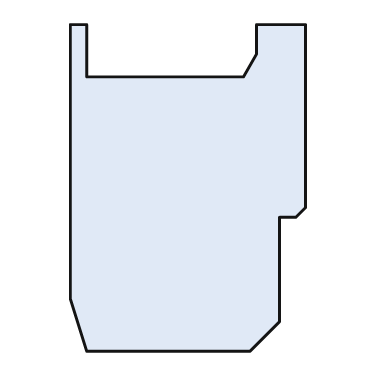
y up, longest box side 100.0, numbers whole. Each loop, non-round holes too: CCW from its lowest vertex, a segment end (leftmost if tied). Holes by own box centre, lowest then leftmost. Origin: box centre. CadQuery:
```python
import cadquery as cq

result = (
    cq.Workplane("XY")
    .moveTo(-31.0, -50.0)
    .lineTo(19.0, -50.0)
    .lineTo(28.0, -41.0)
    .lineTo(28.0, -9.0)
    .lineTo(33.0, -9.0)
    .lineTo(36.0, -6.0)
    .lineTo(36.0, 50.0)
    .lineTo(21.0, 50.0)
    .lineTo(21.0, 41.0)
    .lineTo(17.0, 34.0)
    .lineTo(-31.0, 34.0)
    .lineTo(-31.0, 50.0)
    .lineTo(-36.0, 50.0)
    .lineTo(-36.0, -34.0)
    .close()
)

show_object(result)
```